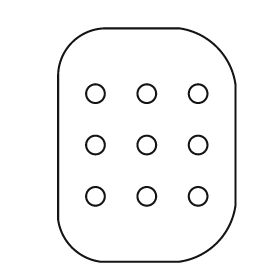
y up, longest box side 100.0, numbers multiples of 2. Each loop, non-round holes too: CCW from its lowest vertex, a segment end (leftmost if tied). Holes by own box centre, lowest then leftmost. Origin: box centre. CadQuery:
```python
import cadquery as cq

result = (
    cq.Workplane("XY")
    .moveTo(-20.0, -50.0)
    .lineTo(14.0, -50.0)
    .threePointArc((30.0, -42.0), (38.0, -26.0))
    .lineTo(38.0, 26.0)
    .threePointArc((30.0, 42.0), (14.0, 50.0))
    .lineTo(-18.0, 50.0)
    .threePointArc((-32.0, 44.0), (-38.0, 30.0))
    .lineTo(-38.0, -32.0)
    .threePointArc((-32.0, -44.0), (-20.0, -50.0))
    .close()
    .moveTo(-22.0, -22.0)
    .circle(4.0)
    .moveTo(0.0, -22.0)
    .circle(4.0)
    .moveTo(22.0, -22.0)
    .circle(4.0)
    .moveTo(-22.0, 0.0)
    .circle(4.0)
    .moveTo(0.0, 0.0)
    .circle(4.0)
    .moveTo(22.0, 0.0)
    .circle(4.0)
    .moveTo(-22.0, 22.0)
    .circle(4.0)
    .moveTo(0.0, 22.0)
    .circle(4.0)
    .moveTo(22.0, 22.0)
    .circle(4.0)
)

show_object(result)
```